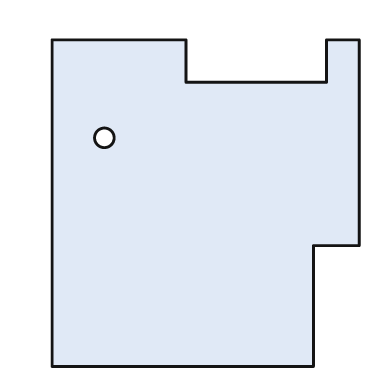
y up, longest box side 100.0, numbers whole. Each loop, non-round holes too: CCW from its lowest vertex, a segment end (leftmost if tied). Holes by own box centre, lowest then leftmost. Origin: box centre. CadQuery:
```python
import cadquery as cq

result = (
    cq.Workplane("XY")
    .moveTo(-47.0, -50.0)
    .lineTo(33.0, -50.0)
    .lineTo(33.0, -13.0)
    .lineTo(47.0, -13.0)
    .lineTo(47.0, 50.0)
    .lineTo(37.0, 50.0)
    .lineTo(37.0, 37.0)
    .lineTo(-6.0, 37.0)
    .lineTo(-6.0, 50.0)
    .lineTo(-47.0, 50.0)
    .close()
    .moveTo(-31.0, 20.0)
    .circle(3.0)
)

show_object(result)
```